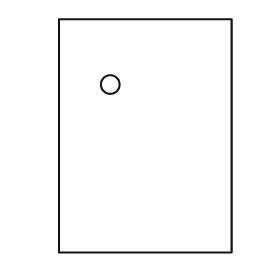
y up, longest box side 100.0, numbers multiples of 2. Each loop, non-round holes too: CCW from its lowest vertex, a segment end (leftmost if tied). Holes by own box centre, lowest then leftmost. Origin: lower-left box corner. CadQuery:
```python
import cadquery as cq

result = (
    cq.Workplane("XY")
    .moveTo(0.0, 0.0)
    .lineTo(74.0, 0.0)
    .lineTo(74.0, 100.0)
    .lineTo(0.0, 100.0)
    .close()
    .moveTo(22.0, 72.0)
    .circle(4.0)
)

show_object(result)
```